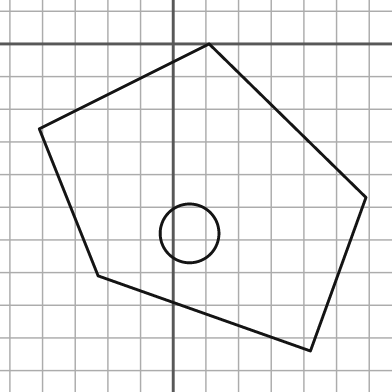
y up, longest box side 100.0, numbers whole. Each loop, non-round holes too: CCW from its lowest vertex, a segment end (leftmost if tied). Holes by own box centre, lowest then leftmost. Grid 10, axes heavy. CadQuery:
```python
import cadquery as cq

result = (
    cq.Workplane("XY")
    .moveTo(42.0, -94.0)
    .lineTo(59.0, -47.0)
    .lineTo(11.0, 0.0)
    .lineTo(-41.0, -26.0)
    .lineTo(-23.0, -71.0)
    .close()
    .moveTo(5.0, -58.0)
    .circle(9.0)
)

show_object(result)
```